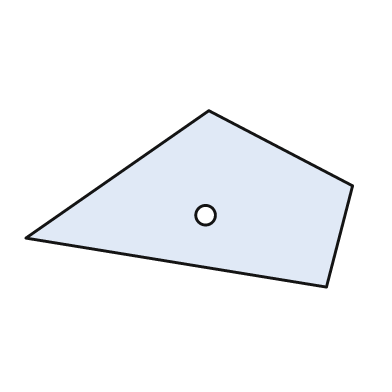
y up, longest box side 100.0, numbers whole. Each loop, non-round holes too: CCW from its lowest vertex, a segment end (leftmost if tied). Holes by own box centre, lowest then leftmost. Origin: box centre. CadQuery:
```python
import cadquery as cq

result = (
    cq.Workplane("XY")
    .moveTo(42.0, -27.0)
    .lineTo(50.0, 4.0)
    .lineTo(6.0, 27.0)
    .lineTo(-50.0, -12.0)
    .close()
    .moveTo(5.0, -5.0)
    .circle(3.0)
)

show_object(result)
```